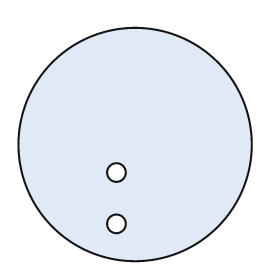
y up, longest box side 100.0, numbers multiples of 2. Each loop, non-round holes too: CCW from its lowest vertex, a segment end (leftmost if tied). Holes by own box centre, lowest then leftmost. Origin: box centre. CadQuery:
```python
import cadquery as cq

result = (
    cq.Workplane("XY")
    .moveTo(0.0, 0.0)
    .circle(50.0)
    .moveTo(-8.0, -34.0)
    .circle(4.0)
    .moveTo(-8.0, -12.0)
    .circle(4.0)
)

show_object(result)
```